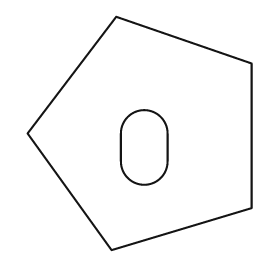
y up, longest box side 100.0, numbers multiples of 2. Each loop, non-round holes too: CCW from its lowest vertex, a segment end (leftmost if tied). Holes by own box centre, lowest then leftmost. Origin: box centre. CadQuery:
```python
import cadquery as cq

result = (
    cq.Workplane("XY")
    .moveTo(-12.0, -50.0)
    .lineTo(48.0, -32.0)
    .lineTo(48.0, 30.0)
    .lineTo(-10.0, 50.0)
    .lineTo(-48.0, 0.0)
    .close()
    .moveTo(-8.0, -12.0)
    .threePointArc((2.0, -22.0), (12.0, -12.0))
    .lineTo(12.0, 0.0)
    .threePointArc((2.0, 10.0), (-8.0, 0.0))
    .close()
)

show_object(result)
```